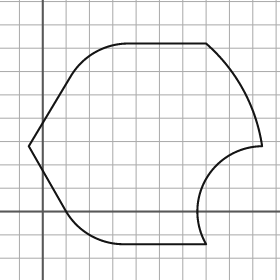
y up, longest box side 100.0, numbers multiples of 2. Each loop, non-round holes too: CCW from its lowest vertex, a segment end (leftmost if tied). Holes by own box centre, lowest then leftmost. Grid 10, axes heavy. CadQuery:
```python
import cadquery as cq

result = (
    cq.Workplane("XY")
    .moveTo(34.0, -14.0)
    .lineTo(70.0, -14.0)
    .threePointArc((70.0, 14.0), (94.0, 28.0))
    .threePointArc((86.0, 52.0), (70.0, 72.0))
    .lineTo(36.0, 72.0)
    .threePointArc((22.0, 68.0), (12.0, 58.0))
    .lineTo(-6.0, 28.0)
    .lineTo(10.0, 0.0)
    .threePointArc((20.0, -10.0), (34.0, -14.0))
    .close()
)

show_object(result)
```